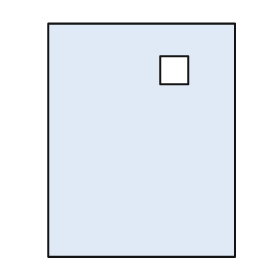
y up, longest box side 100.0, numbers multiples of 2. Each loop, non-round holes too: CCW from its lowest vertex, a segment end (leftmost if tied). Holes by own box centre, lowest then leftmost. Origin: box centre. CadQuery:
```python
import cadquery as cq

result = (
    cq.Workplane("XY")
    .moveTo(-40.0, -50.0)
    .lineTo(40.0, -50.0)
    .lineTo(40.0, 50.0)
    .lineTo(-40.0, 50.0)
    .close()
    .moveTo(8.0, 24.0)
    .lineTo(20.0, 24.0)
    .lineTo(20.0, 36.0)
    .lineTo(8.0, 36.0)
    .close()
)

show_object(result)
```